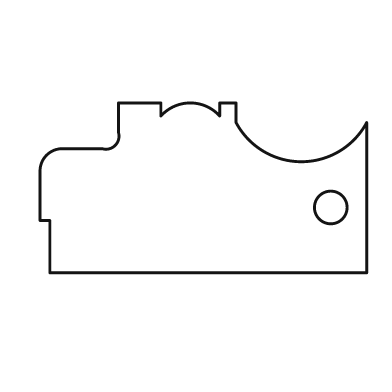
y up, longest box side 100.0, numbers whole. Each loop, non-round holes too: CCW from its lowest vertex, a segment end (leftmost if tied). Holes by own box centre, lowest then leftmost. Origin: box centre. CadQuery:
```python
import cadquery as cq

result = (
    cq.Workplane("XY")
    .moveTo(-47.0, -26.0)
    .lineTo(50.0, -26.0)
    .lineTo(50.0, 20.0)
    .threePointArc((30.0, 8.0), (10.0, 20.0))
    .lineTo(10.0, 26.0)
    .lineTo(5.0, 26.0)
    .lineTo(5.0, 22.0)
    .threePointArc((-4.0, 26.0), (-13.0, 22.0))
    .lineTo(-13.0, 26.0)
    .lineTo(-26.0, 26.0)
    .lineTo(-26.0, 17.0)
    .threePointArc((-27.0, 13.0), (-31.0, 12.0))
    .lineTo(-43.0, 12.0)
    .threePointArc((-48.0, 10.0), (-50.0, 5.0))
    .lineTo(-50.0, -10.0)
    .lineTo(-47.0, -10.0)
    .close()
    .moveTo(39.0, -6.0)
    .circle(5.0)
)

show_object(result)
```